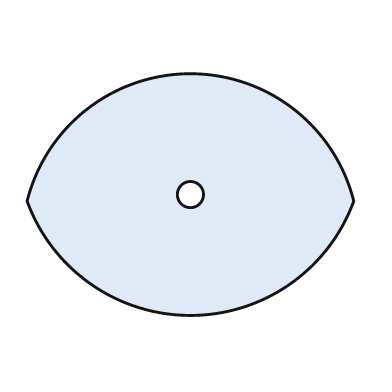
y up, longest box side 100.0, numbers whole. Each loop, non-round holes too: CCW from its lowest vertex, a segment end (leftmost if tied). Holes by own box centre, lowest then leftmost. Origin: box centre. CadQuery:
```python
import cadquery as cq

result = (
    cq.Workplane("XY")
    .moveTo(-50.0, -2.0)
    .threePointArc((0.0, -37.0), (50.0, -2.0))
    .threePointArc((0.0, 37.0), (-50.0, -2.0))
    .close()
    .moveTo(0.0, 0.0)
    .circle(4.0)
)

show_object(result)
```